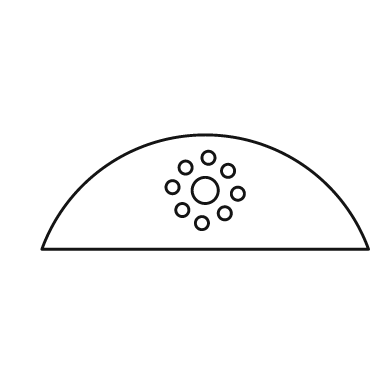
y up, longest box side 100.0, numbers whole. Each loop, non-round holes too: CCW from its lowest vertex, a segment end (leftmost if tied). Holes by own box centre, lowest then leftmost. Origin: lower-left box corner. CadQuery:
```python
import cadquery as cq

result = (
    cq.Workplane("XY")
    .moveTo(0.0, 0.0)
    .lineTo(100.0, 0.0)
    .threePointArc((50.0, 35.0), (0.0, 0.0))
    .close()
    .moveTo(49.0, 8.0)
    .circle(2.0)
    .moveTo(56.0, 11.0)
    .circle(2.0)
    .moveTo(43.0, 12.0)
    .circle(2.0)
    .moveTo(60.0, 17.0)
    .circle(2.0)
    .moveTo(50.0, 18.0)
    .circle(4.0)
    .moveTo(40.0, 19.0)
    .circle(2.0)
    .moveTo(57.0, 24.0)
    .circle(2.0)
    .moveTo(44.0, 25.0)
    .circle(2.0)
    .moveTo(51.0, 28.0)
    .circle(2.0)
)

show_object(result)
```